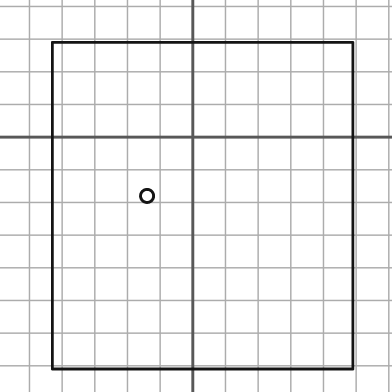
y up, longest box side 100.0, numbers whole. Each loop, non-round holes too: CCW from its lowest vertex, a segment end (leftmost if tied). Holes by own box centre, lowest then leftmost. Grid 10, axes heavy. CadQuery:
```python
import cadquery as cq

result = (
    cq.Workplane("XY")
    .moveTo(-43.0, -71.0)
    .lineTo(49.0, -71.0)
    .lineTo(49.0, 29.0)
    .lineTo(-43.0, 29.0)
    .close()
    .moveTo(-14.0, -18.0)
    .circle(2.0)
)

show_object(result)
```